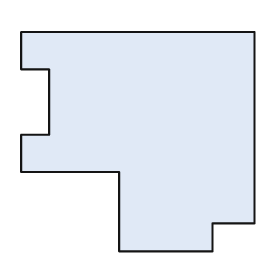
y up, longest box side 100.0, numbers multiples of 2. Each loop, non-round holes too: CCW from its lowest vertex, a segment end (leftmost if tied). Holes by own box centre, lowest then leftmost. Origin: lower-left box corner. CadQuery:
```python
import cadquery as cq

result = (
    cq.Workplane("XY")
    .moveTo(42.0, 0.0)
    .lineTo(82.0, 0.0)
    .lineTo(82.0, 12.0)
    .lineTo(100.0, 12.0)
    .lineTo(100.0, 94.0)
    .lineTo(0.0, 94.0)
    .lineTo(0.0, 78.0)
    .lineTo(12.0, 78.0)
    .lineTo(12.0, 50.0)
    .lineTo(0.0, 50.0)
    .lineTo(0.0, 34.0)
    .lineTo(42.0, 34.0)
    .close()
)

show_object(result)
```